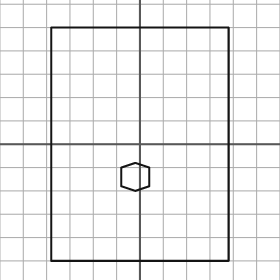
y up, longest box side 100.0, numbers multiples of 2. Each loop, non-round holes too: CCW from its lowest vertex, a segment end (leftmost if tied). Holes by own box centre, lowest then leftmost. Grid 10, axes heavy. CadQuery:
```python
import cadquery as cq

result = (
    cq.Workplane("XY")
    .moveTo(-38.0, -50.0)
    .lineTo(38.0, -50.0)
    .lineTo(38.0, 50.0)
    .lineTo(-38.0, 50.0)
    .close()
    .moveTo(-2.0, -20.0)
    .lineTo(4.0, -18.0)
    .lineTo(4.0, -10.0)
    .lineTo(-2.0, -8.0)
    .lineTo(-8.0, -10.0)
    .lineTo(-8.0, -18.0)
    .close()
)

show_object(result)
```